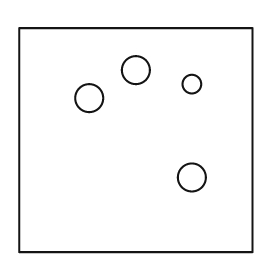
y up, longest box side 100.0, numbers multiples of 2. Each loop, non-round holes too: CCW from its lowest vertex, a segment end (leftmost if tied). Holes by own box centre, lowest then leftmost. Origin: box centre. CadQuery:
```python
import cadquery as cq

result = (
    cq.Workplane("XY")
    .moveTo(-50.0, -48.0)
    .lineTo(50.0, -48.0)
    .lineTo(50.0, 48.0)
    .lineTo(-50.0, 48.0)
    .close()
    .moveTo(24.0, -16.0)
    .circle(6.0)
    .moveTo(-20.0, 18.0)
    .circle(6.0)
    .moveTo(24.0, 24.0)
    .circle(4.0)
    .moveTo(0.0, 30.0)
    .circle(6.0)
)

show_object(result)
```